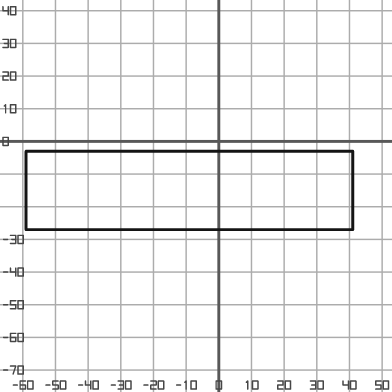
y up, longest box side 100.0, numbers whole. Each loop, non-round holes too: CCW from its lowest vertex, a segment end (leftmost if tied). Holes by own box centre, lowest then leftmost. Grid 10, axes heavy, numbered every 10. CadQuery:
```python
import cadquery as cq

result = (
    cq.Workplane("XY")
    .moveTo(-59.0, -27.0)
    .lineTo(41.0, -27.0)
    .lineTo(41.0, -3.0)
    .lineTo(-59.0, -3.0)
    .close()
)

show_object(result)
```